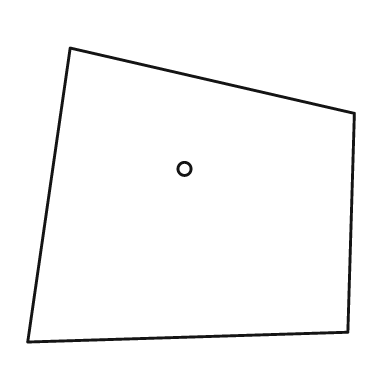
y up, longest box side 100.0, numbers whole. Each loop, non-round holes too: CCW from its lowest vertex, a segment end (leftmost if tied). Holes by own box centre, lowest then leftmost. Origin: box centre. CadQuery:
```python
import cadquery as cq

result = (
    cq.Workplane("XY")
    .moveTo(-50.0, -45.0)
    .lineTo(48.0, -42.0)
    .lineTo(50.0, 25.0)
    .lineTo(-37.0, 45.0)
    .close()
    .moveTo(-2.0, 8.0)
    .circle(2.0)
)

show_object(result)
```